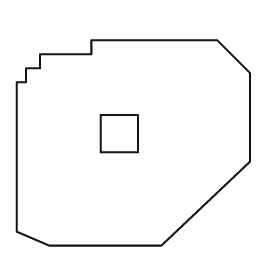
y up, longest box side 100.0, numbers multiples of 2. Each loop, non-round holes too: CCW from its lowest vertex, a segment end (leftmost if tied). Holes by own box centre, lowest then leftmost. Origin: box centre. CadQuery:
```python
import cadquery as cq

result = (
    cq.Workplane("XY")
    .moveTo(-36.0, -44.0)
    .lineTo(12.0, -44.0)
    .lineTo(50.0, -8.0)
    .lineTo(50.0, 30.0)
    .lineTo(36.0, 44.0)
    .lineTo(-18.0, 44.0)
    .lineTo(-18.0, 38.0)
    .lineTo(-40.0, 38.0)
    .lineTo(-40.0, 32.0)
    .lineTo(-46.0, 32.0)
    .lineTo(-46.0, 26.0)
    .lineTo(-50.0, 26.0)
    .lineTo(-50.0, -38.0)
    .close()
    .moveTo(-14.0, -4.0)
    .lineTo(2.0, -4.0)
    .lineTo(2.0, 12.0)
    .lineTo(-14.0, 12.0)
    .close()
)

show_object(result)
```